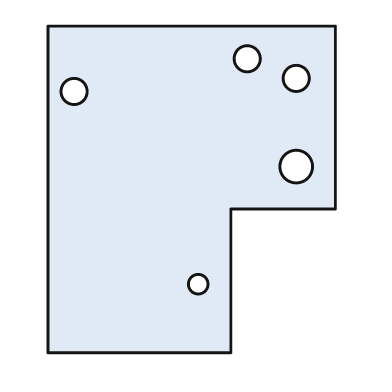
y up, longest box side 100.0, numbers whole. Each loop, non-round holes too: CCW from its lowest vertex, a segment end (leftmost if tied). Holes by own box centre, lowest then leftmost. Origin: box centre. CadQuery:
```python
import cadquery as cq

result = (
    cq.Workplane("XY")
    .moveTo(-44.0, -50.0)
    .lineTo(12.0, -50.0)
    .lineTo(12.0, -6.0)
    .lineTo(44.0, -6.0)
    .lineTo(44.0, 50.0)
    .lineTo(-44.0, 50.0)
    .close()
    .moveTo(2.0, -29.0)
    .circle(3.0)
    .moveTo(32.0, 7.0)
    .circle(5.0)
    .moveTo(-36.0, 30.0)
    .circle(4.0)
    .moveTo(32.0, 34.0)
    .circle(4.0)
    .moveTo(17.0, 40.0)
    .circle(4.0)
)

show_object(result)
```